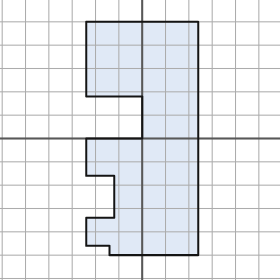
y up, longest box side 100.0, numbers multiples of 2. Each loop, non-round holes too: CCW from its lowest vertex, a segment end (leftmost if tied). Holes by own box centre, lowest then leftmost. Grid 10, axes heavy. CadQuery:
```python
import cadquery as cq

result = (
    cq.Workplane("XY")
    .moveTo(-14.0, -50.0)
    .lineTo(24.0, -50.0)
    .lineTo(24.0, 50.0)
    .lineTo(-24.0, 50.0)
    .lineTo(-24.0, 18.0)
    .lineTo(0.0, 18.0)
    .lineTo(0.0, 0.0)
    .lineTo(-24.0, 0.0)
    .lineTo(-24.0, -16.0)
    .lineTo(-12.0, -16.0)
    .lineTo(-12.0, -34.0)
    .lineTo(-24.0, -34.0)
    .lineTo(-24.0, -46.0)
    .lineTo(-14.0, -46.0)
    .close()
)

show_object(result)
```